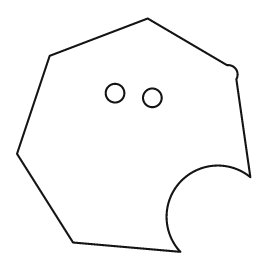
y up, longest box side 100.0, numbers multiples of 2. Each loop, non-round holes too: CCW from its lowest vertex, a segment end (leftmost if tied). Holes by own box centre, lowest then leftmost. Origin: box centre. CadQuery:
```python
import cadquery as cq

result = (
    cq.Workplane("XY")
    .moveTo(20.0, -50.0)
    .threePointArc((20.0, -20.0), (50.0, -18.0))
    .lineTo(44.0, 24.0)
    .threePointArc((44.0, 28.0), (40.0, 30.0))
    .lineTo(6.0, 50.0)
    .lineTo(-36.0, 34.0)
    .lineTo(-50.0, -8.0)
    .lineTo(-26.0, -46.0)
    .close()
    .moveTo(8.0, 16.0)
    .circle(4.0)
    .moveTo(-8.0, 18.0)
    .circle(4.0)
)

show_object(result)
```